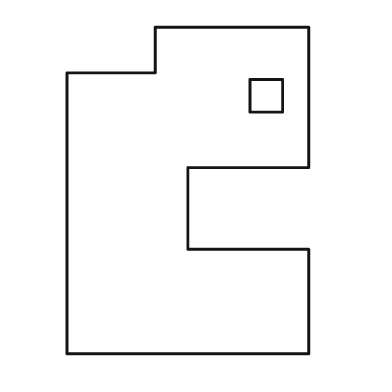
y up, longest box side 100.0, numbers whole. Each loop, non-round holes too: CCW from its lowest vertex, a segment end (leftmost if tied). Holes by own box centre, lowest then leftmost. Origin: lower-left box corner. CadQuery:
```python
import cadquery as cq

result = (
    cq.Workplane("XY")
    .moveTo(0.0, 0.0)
    .lineTo(74.0, 0.0)
    .lineTo(74.0, 32.0)
    .lineTo(37.0, 32.0)
    .lineTo(37.0, 57.0)
    .lineTo(74.0, 57.0)
    .lineTo(74.0, 100.0)
    .lineTo(27.0, 100.0)
    .lineTo(27.0, 86.0)
    .lineTo(0.0, 86.0)
    .close()
    .moveTo(56.0, 74.0)
    .lineTo(66.0, 74.0)
    .lineTo(66.0, 84.0)
    .lineTo(56.0, 84.0)
    .close()
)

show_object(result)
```